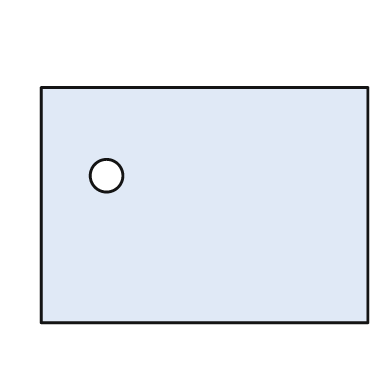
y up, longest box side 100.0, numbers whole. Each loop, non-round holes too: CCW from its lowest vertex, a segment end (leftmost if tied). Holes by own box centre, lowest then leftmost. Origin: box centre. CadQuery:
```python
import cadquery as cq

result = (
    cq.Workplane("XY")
    .moveTo(-50.0, -36.0)
    .lineTo(50.0, -36.0)
    .lineTo(50.0, 36.0)
    .lineTo(-50.0, 36.0)
    .close()
    .moveTo(-30.0, 9.0)
    .circle(5.0)
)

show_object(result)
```